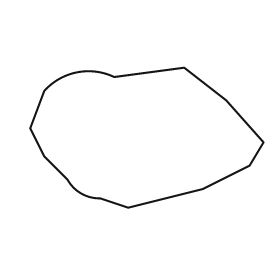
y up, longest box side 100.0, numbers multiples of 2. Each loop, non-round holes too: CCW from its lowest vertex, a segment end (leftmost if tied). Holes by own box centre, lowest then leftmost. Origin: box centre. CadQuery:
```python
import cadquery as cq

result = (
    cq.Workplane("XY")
    .moveTo(-8.0, -30.0)
    .lineTo(24.0, -22.0)
    .lineTo(44.0, -12.0)
    .lineTo(50.0, -2.0)
    .lineTo(34.0, 16.0)
    .lineTo(16.0, 30.0)
    .lineTo(-14.0, 26.0)
    .threePointArc((-30.0, 28.0), (-44.0, 20.0))
    .lineTo(-50.0, 4.0)
    .lineTo(-44.0, -8.0)
    .lineTo(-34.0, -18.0)
    .threePointArc((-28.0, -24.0), (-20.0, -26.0))
    .close()
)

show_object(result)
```